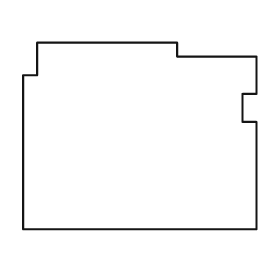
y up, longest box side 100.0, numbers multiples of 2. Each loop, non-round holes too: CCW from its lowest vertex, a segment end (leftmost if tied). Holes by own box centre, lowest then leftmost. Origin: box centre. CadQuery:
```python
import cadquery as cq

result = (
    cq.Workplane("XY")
    .moveTo(-50.0, -40.0)
    .lineTo(50.0, -40.0)
    .lineTo(50.0, 6.0)
    .lineTo(44.0, 6.0)
    .lineTo(44.0, 18.0)
    .lineTo(50.0, 18.0)
    .lineTo(50.0, 34.0)
    .lineTo(16.0, 34.0)
    .lineTo(16.0, 40.0)
    .lineTo(-44.0, 40.0)
    .lineTo(-44.0, 26.0)
    .lineTo(-50.0, 26.0)
    .close()
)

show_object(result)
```